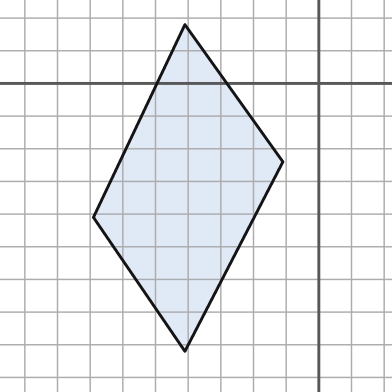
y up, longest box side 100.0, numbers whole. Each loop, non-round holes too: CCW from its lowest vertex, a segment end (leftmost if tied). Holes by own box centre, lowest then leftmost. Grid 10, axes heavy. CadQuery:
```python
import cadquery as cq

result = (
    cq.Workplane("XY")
    .moveTo(-41.0, -82.0)
    .lineTo(-11.0, -24.0)
    .lineTo(-41.0, 18.0)
    .lineTo(-69.0, -41.0)
    .close()
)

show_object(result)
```